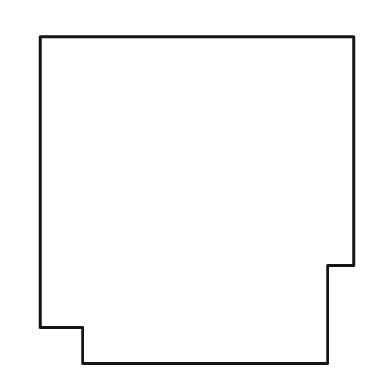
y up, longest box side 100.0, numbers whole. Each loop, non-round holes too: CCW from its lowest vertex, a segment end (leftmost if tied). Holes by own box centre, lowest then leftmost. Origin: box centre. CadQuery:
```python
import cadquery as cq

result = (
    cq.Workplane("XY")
    .moveTo(-35.0, -50.0)
    .lineTo(40.0, -50.0)
    .lineTo(40.0, -20.0)
    .lineTo(48.0, -20.0)
    .lineTo(48.0, 50.0)
    .lineTo(-48.0, 50.0)
    .lineTo(-48.0, -39.0)
    .lineTo(-35.0, -39.0)
    .close()
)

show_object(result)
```